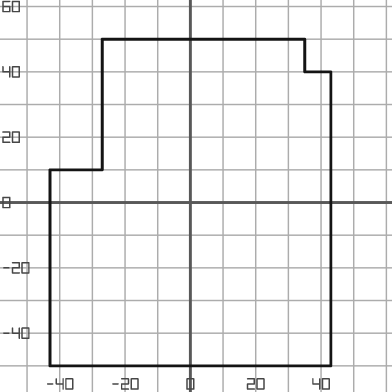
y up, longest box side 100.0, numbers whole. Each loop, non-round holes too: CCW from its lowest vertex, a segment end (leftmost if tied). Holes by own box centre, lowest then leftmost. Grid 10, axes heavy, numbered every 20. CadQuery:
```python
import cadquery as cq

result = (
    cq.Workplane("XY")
    .moveTo(-43.0, -50.0)
    .lineTo(43.0, -50.0)
    .lineTo(43.0, 40.0)
    .lineTo(35.0, 40.0)
    .lineTo(35.0, 50.0)
    .lineTo(-27.0, 50.0)
    .lineTo(-27.0, 10.0)
    .lineTo(-43.0, 10.0)
    .close()
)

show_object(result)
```